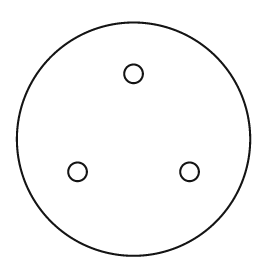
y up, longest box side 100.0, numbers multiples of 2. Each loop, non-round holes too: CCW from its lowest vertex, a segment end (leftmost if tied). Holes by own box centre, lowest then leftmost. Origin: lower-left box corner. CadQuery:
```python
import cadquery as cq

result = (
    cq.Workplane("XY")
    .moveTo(50.0, 50.0)
    .circle(50.0)
    .moveTo(26.0, 36.0)
    .circle(4.0)
    .moveTo(74.0, 36.0)
    .circle(4.0)
    .moveTo(50.0, 78.0)
    .circle(4.0)
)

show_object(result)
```